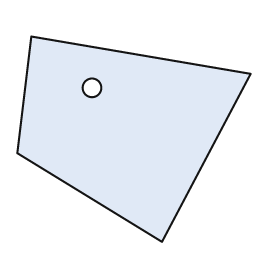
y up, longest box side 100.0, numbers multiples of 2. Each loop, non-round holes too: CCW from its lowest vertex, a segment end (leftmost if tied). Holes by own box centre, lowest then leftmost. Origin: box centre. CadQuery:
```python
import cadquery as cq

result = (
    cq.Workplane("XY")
    .moveTo(12.0, -44.0)
    .lineTo(50.0, 28.0)
    .lineTo(-44.0, 44.0)
    .lineTo(-50.0, -6.0)
    .close()
    .moveTo(-18.0, 22.0)
    .circle(4.0)
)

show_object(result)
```